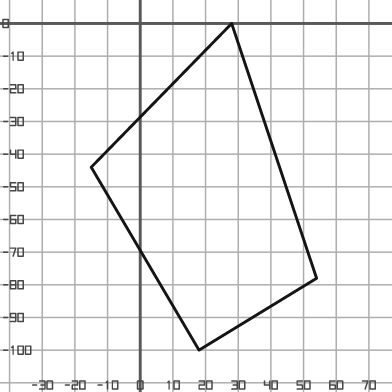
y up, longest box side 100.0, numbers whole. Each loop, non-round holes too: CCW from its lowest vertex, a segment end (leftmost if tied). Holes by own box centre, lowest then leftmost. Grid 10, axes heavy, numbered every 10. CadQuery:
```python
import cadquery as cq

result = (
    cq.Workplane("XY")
    .moveTo(18.0, -100.0)
    .lineTo(54.0, -78.0)
    .lineTo(28.0, 0.0)
    .lineTo(-15.0, -44.0)
    .close()
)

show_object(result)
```